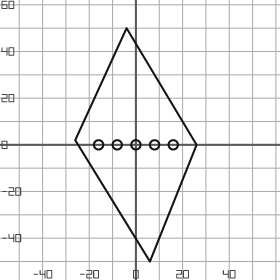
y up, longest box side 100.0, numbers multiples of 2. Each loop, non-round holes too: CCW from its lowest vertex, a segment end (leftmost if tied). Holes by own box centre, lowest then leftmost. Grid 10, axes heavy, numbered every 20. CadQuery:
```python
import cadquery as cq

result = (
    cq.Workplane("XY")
    .moveTo(6.0, -50.0)
    .lineTo(26.0, 0.0)
    .lineTo(-4.0, 50.0)
    .lineTo(-26.0, 2.0)
    .close()
    .moveTo(-16.0, 0.0)
    .circle(2.0)
    .moveTo(-8.0, 0.0)
    .circle(2.0)
    .moveTo(0.0, 0.0)
    .circle(2.0)
    .moveTo(8.0, 0.0)
    .circle(2.0)
    .moveTo(16.0, 0.0)
    .circle(2.0)
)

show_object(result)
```